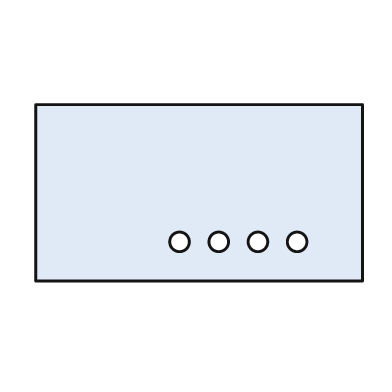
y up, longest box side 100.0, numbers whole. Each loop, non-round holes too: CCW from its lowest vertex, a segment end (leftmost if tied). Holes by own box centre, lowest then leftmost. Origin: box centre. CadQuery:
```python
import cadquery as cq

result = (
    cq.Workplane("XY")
    .moveTo(-50.0, -27.0)
    .lineTo(50.0, -27.0)
    .lineTo(50.0, 27.0)
    .lineTo(-50.0, 27.0)
    .close()
    .moveTo(-6.0, -15.0)
    .circle(3.0)
    .moveTo(6.0, -15.0)
    .circle(3.0)
    .moveTo(18.0, -15.0)
    .circle(3.0)
    .moveTo(30.0, -15.0)
    .circle(3.0)
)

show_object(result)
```